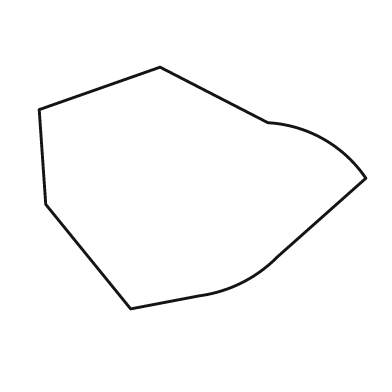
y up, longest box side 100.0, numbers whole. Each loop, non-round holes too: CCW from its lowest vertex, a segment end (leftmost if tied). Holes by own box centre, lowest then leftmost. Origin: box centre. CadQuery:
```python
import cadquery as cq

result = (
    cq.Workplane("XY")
    .moveTo(-22.0, -37.0)
    .lineTo(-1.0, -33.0)
    .threePointArc((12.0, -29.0), (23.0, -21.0))
    .lineTo(50.0, 3.0)
    .threePointArc((37.0, 15.0), (20.0, 20.0))
    .lineTo(-13.0, 37.0)
    .lineTo(-50.0, 24.0)
    .lineTo(-48.0, -5.0)
    .close()
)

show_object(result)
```